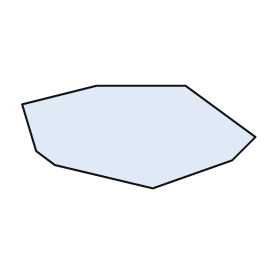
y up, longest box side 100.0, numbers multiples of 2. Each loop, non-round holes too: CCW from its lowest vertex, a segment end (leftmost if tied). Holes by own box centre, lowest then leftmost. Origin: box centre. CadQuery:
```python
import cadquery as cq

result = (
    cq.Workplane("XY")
    .moveTo(6.0, -22.0)
    .lineTo(40.0, -10.0)
    .lineTo(50.0, 0.0)
    .lineTo(20.0, 22.0)
    .lineTo(-18.0, 22.0)
    .lineTo(-50.0, 14.0)
    .lineTo(-44.0, -6.0)
    .lineTo(-36.0, -12.0)
    .close()
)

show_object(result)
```